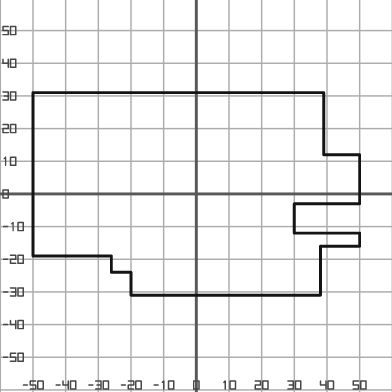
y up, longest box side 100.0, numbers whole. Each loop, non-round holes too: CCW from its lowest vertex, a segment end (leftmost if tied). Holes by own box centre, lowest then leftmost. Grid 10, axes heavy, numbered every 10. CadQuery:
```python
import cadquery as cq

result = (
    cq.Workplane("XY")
    .moveTo(-20.0, -31.0)
    .lineTo(38.0, -31.0)
    .lineTo(38.0, -16.0)
    .lineTo(50.0, -16.0)
    .lineTo(50.0, -12.0)
    .lineTo(30.0, -12.0)
    .lineTo(30.0, -3.0)
    .lineTo(50.0, -3.0)
    .lineTo(50.0, 12.0)
    .lineTo(39.0, 12.0)
    .lineTo(39.0, 31.0)
    .lineTo(-50.0, 31.0)
    .lineTo(-50.0, -19.0)
    .lineTo(-26.0, -19.0)
    .lineTo(-26.0, -24.0)
    .lineTo(-20.0, -24.0)
    .close()
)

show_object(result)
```